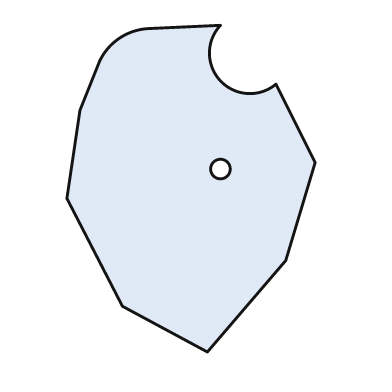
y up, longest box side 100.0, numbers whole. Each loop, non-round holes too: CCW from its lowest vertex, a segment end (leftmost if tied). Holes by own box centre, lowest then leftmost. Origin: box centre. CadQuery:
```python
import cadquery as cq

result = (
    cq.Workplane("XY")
    .moveTo(5.0, -50.0)
    .lineTo(29.0, -22.0)
    .lineTo(38.0, 8.0)
    .lineTo(26.0, 32.0)
    .threePointArc((9.0, 33.0), (9.0, 50.0))
    .lineTo(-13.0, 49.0)
    .threePointArc((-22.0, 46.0), (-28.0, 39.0))
    .lineTo(-34.0, 24.0)
    .lineTo(-38.0, -3.0)
    .lineTo(-21.0, -36.0)
    .close()
    .moveTo(9.0, 6.0)
    .circle(3.0)
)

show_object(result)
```